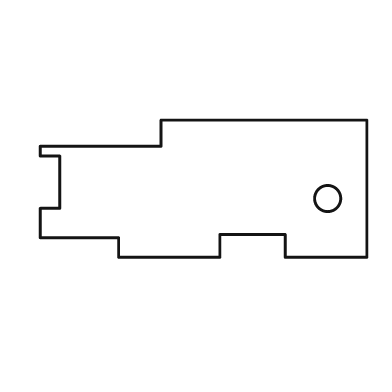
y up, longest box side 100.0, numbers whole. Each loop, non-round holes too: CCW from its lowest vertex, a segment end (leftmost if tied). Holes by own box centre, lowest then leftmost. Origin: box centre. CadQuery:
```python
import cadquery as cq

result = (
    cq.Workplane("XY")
    .moveTo(-26.0, -21.0)
    .lineTo(5.0, -21.0)
    .lineTo(5.0, -14.0)
    .lineTo(25.0, -14.0)
    .lineTo(25.0, -21.0)
    .lineTo(50.0, -21.0)
    .lineTo(50.0, 21.0)
    .lineTo(-13.0, 21.0)
    .lineTo(-13.0, 13.0)
    .lineTo(-50.0, 13.0)
    .lineTo(-50.0, 10.0)
    .lineTo(-44.0, 10.0)
    .lineTo(-44.0, -6.0)
    .lineTo(-50.0, -6.0)
    .lineTo(-50.0, -15.0)
    .lineTo(-26.0, -15.0)
    .close()
    .moveTo(38.0, -3.0)
    .circle(4.0)
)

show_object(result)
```